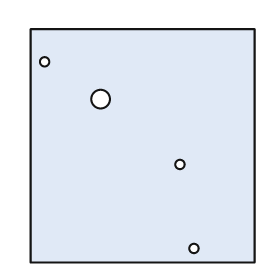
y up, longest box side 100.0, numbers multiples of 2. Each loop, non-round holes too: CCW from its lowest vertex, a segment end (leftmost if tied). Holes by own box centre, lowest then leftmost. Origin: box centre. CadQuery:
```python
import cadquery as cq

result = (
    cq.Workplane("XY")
    .moveTo(-48.0, -50.0)
    .lineTo(48.0, -50.0)
    .lineTo(48.0, 50.0)
    .lineTo(-48.0, 50.0)
    .close()
    .moveTo(22.0, -44.0)
    .circle(2.0)
    .moveTo(16.0, -8.0)
    .circle(2.0)
    .moveTo(-18.0, 20.0)
    .circle(4.0)
    .moveTo(-42.0, 36.0)
    .circle(2.0)
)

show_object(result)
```